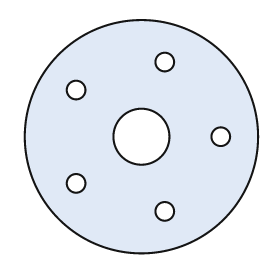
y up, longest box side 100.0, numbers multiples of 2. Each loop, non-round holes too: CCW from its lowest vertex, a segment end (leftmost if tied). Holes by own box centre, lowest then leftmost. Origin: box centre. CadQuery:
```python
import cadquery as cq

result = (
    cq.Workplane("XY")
    .moveTo(0.0, 0.0)
    .circle(50.0)
    .moveTo(10.0, -32.0)
    .circle(4.0)
    .moveTo(-28.0, -20.0)
    .circle(4.0)
    .moveTo(0.0, 0.0)
    .circle(12.0)
    .moveTo(34.0, 0.0)
    .circle(4.0)
    .moveTo(-28.0, 20.0)
    .circle(4.0)
    .moveTo(10.0, 32.0)
    .circle(4.0)
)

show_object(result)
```